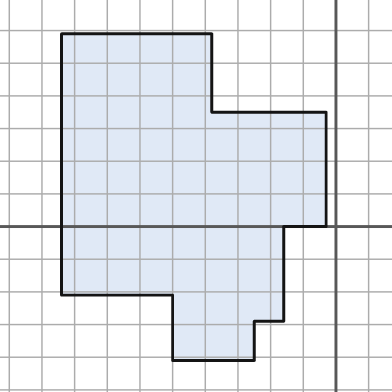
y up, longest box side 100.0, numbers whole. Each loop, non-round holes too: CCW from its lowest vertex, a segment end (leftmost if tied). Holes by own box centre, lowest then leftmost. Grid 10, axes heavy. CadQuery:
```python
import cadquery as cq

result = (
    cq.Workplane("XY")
    .moveTo(-50.0, -41.0)
    .lineTo(-25.0, -41.0)
    .lineTo(-25.0, -29.0)
    .lineTo(-16.0, -29.0)
    .lineTo(-16.0, 0.0)
    .lineTo(-3.0, 0.0)
    .lineTo(-3.0, 35.0)
    .lineTo(-38.0, 35.0)
    .lineTo(-38.0, 59.0)
    .lineTo(-84.0, 59.0)
    .lineTo(-84.0, -21.0)
    .lineTo(-50.0, -21.0)
    .close()
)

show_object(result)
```